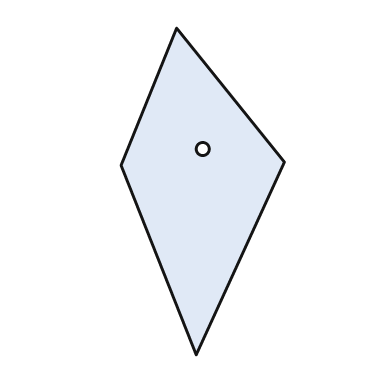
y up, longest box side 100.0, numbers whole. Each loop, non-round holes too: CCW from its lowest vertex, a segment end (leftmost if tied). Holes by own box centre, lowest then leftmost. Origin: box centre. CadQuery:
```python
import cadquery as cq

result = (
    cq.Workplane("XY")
    .moveTo(-2.0, -50.0)
    .lineTo(25.0, 9.0)
    .lineTo(-8.0, 50.0)
    .lineTo(-25.0, 8.0)
    .close()
    .moveTo(0.0, 13.0)
    .circle(2.0)
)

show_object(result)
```